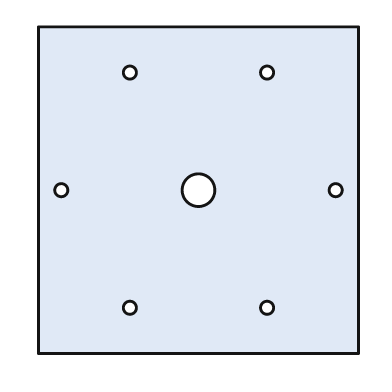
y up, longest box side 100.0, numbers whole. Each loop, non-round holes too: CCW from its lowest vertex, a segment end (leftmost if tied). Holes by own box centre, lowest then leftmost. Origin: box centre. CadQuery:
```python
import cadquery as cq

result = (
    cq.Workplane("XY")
    .moveTo(-49.0, -50.0)
    .lineTo(49.0, -50.0)
    .lineTo(49.0, 50.0)
    .lineTo(-49.0, 50.0)
    .close()
    .moveTo(-21.0, -36.0)
    .circle(2.0)
    .moveTo(21.0, -36.0)
    .circle(2.0)
    .moveTo(-42.0, 0.0)
    .circle(2.0)
    .moveTo(0.0, 0.0)
    .circle(5.0)
    .moveTo(42.0, 0.0)
    .circle(2.0)
    .moveTo(-21.0, 36.0)
    .circle(2.0)
    .moveTo(21.0, 36.0)
    .circle(2.0)
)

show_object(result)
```